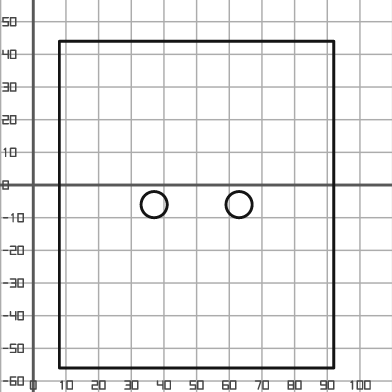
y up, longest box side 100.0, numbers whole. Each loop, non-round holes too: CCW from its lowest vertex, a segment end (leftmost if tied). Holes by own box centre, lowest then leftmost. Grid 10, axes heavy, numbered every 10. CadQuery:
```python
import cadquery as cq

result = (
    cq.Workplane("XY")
    .moveTo(8.0, -56.0)
    .lineTo(92.0, -56.0)
    .lineTo(92.0, 44.0)
    .lineTo(8.0, 44.0)
    .close()
    .moveTo(37.0, -6.0)
    .circle(4.0)
    .moveTo(63.0, -6.0)
    .circle(4.0)
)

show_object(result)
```